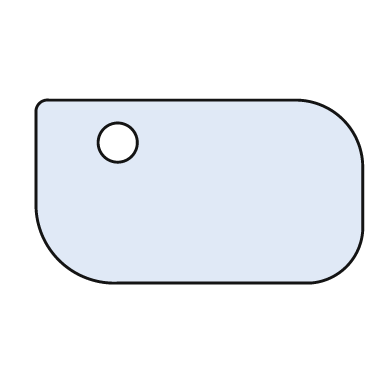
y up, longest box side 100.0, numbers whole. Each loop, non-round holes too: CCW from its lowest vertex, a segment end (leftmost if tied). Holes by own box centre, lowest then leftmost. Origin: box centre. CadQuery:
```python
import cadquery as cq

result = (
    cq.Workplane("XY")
    .moveTo(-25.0, -28.0)
    .lineTo(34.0, -28.0)
    .threePointArc((45.0, -23.0), (50.0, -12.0))
    .lineTo(50.0, 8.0)
    .threePointArc((44.0, 22.0), (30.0, 28.0))
    .lineTo(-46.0, 28.0)
    .threePointArc((-49.0, 27.0), (-50.0, 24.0))
    .lineTo(-50.0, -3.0)
    .threePointArc((-43.0, -21.0), (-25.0, -28.0))
    .close()
    .moveTo(-25.0, 15.0)
    .circle(6.0)
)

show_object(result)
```